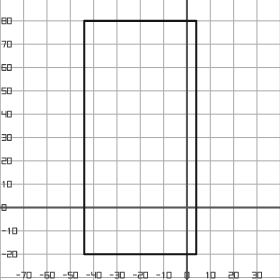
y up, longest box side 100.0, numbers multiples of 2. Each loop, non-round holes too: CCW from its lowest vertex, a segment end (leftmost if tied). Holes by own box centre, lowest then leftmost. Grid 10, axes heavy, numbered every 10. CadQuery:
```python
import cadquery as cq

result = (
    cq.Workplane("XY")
    .moveTo(-44.0, -20.0)
    .lineTo(4.0, -20.0)
    .lineTo(4.0, 80.0)
    .lineTo(-44.0, 80.0)
    .close()
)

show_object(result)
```